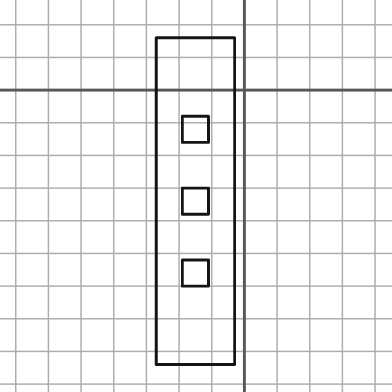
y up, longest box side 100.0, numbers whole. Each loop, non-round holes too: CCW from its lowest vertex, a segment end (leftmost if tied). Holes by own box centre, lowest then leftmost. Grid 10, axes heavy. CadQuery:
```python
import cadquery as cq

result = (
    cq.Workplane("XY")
    .moveTo(-27.0, -84.0)
    .lineTo(-3.0, -84.0)
    .lineTo(-3.0, 16.0)
    .lineTo(-27.0, 16.0)
    .close()
    .moveTo(-19.0, -60.0)
    .lineTo(-11.0, -60.0)
    .lineTo(-11.0, -52.0)
    .lineTo(-19.0, -52.0)
    .close()
    .moveTo(-19.0, -38.0)
    .lineTo(-11.0, -38.0)
    .lineTo(-11.0, -30.0)
    .lineTo(-19.0, -30.0)
    .close()
    .moveTo(-19.0, -16.0)
    .lineTo(-11.0, -16.0)
    .lineTo(-11.0, -8.0)
    .lineTo(-19.0, -8.0)
    .close()
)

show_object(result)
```